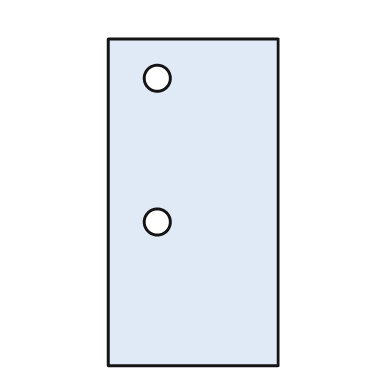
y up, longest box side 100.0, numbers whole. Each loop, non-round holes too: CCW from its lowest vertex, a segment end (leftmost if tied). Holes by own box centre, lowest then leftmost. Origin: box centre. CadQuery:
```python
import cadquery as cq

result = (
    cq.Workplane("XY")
    .moveTo(-26.0, -50.0)
    .lineTo(26.0, -50.0)
    .lineTo(26.0, 50.0)
    .lineTo(-26.0, 50.0)
    .close()
    .moveTo(-11.0, -6.0)
    .circle(4.0)
    .moveTo(-11.0, 38.0)
    .circle(4.0)
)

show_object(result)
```